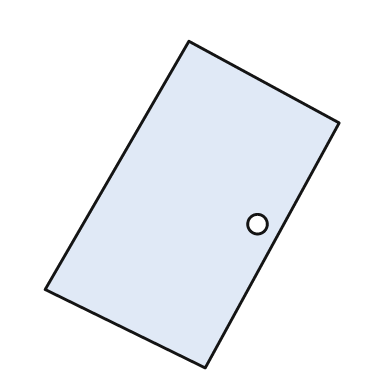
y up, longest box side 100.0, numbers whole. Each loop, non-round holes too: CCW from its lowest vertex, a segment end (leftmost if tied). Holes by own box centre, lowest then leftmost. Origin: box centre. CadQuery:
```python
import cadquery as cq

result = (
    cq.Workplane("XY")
    .moveTo(4.0, -50.0)
    .lineTo(45.0, 25.0)
    .lineTo(-1.0, 50.0)
    .lineTo(-45.0, -26.0)
    .close()
    .moveTo(20.0, -6.0)
    .circle(3.0)
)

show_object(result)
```